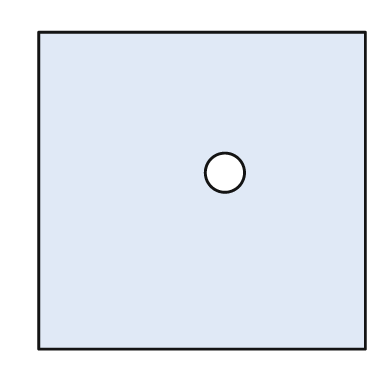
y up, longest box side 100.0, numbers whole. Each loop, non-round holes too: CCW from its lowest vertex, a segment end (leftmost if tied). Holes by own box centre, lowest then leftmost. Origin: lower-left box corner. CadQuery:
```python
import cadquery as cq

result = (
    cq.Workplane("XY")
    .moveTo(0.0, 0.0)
    .lineTo(100.0, 0.0)
    .lineTo(100.0, 97.0)
    .lineTo(0.0, 97.0)
    .close()
    .moveTo(57.0, 54.0)
    .circle(6.0)
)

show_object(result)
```